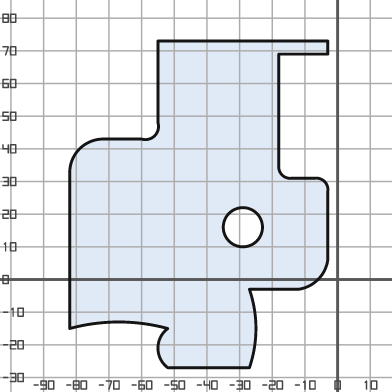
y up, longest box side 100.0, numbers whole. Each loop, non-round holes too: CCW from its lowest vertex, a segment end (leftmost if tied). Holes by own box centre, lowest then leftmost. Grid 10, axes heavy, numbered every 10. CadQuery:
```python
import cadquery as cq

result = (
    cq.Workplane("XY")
    .moveTo(-52.0, -27.0)
    .lineTo(-27.0, -27.0)
    .threePointArc((-25.0, -15.0), (-27.0, -3.0))
    .lineTo(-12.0, -3.0)
    .threePointArc((-6.0, 0.0), (-3.0, 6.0))
    .lineTo(-3.0, 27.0)
    .threePointArc((-4.0, 30.0), (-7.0, 31.0))
    .lineTo(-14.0, 31.0)
    .threePointArc((-17.0, 32.0), (-18.0, 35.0))
    .lineTo(-18.0, 69.0)
    .lineTo(-3.0, 69.0)
    .lineTo(-3.0, 73.0)
    .lineTo(-55.0, 73.0)
    .lineTo(-55.0, 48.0)
    .threePointArc((-56.0, 44.0), (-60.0, 43.0))
    .lineTo(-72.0, 43.0)
    .threePointArc((-79.0, 40.0), (-82.0, 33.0))
    .lineTo(-82.0, -15.0)
    .threePointArc((-67.0, -13.0), (-52.0, -15.0))
    .threePointArc((-55.0, -21.0), (-52.0, -27.0))
    .close()
    .moveTo(-29.0, 16.0)
    .circle(6.0)
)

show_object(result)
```